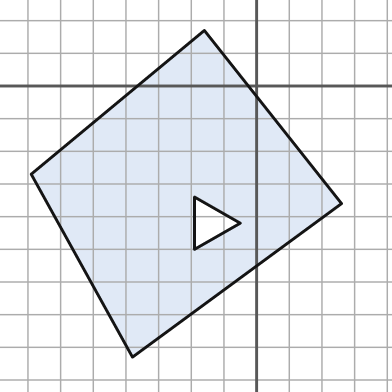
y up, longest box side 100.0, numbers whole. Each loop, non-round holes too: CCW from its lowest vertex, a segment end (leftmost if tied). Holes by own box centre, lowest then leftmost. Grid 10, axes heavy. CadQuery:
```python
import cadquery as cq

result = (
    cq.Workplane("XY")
    .moveTo(-38.0, -83.0)
    .lineTo(26.0, -36.0)
    .lineTo(-16.0, 17.0)
    .lineTo(-69.0, -27.0)
    .close()
    .moveTo(-19.0, -50.0)
    .lineTo(-5.0, -42.0)
    .lineTo(-19.0, -34.0)
    .close()
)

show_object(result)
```